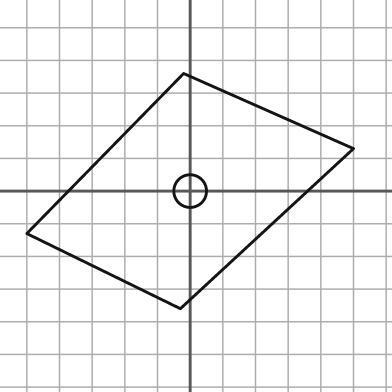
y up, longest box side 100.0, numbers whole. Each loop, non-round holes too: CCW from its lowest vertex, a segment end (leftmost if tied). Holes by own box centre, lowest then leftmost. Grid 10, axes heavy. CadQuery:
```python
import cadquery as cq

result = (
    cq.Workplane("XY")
    .moveTo(-3.0, -36.0)
    .lineTo(50.0, 13.0)
    .lineTo(-2.0, 36.0)
    .lineTo(-50.0, -13.0)
    .close()
    .moveTo(0.0, 0.0)
    .circle(5.0)
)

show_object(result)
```